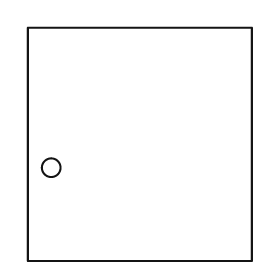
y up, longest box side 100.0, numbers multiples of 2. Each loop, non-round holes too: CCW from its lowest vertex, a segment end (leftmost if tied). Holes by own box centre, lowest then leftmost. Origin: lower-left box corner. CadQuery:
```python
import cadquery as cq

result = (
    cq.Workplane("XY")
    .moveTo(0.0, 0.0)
    .lineTo(96.0, 0.0)
    .lineTo(96.0, 100.0)
    .lineTo(0.0, 100.0)
    .close()
    .moveTo(10.0, 40.0)
    .circle(4.0)
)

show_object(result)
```